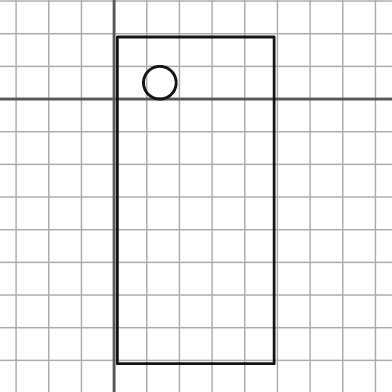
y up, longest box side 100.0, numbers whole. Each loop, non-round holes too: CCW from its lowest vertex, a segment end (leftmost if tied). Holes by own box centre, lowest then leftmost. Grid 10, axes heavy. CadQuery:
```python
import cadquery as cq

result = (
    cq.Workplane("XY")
    .moveTo(1.0, -81.0)
    .lineTo(49.0, -81.0)
    .lineTo(49.0, 19.0)
    .lineTo(1.0, 19.0)
    .close()
    .moveTo(14.0, 5.0)
    .circle(5.0)
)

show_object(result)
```